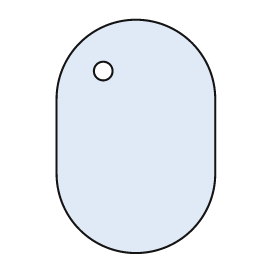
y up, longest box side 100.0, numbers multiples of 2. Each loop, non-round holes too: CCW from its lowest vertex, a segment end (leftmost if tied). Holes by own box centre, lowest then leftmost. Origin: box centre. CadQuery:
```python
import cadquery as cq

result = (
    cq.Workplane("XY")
    .moveTo(-34.0, -16.0)
    .threePointArc((0.0, -50.0), (34.0, -16.0))
    .lineTo(34.0, 16.0)
    .threePointArc((0.0, 50.0), (-34.0, 16.0))
    .close()
    .moveTo(-14.0, 28.0)
    .circle(4.0)
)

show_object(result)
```